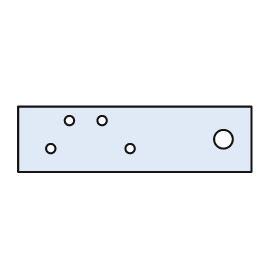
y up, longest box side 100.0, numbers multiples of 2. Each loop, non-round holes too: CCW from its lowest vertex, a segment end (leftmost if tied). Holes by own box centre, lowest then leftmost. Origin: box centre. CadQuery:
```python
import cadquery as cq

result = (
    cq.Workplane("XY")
    .moveTo(-50.0, -14.0)
    .lineTo(50.0, -14.0)
    .lineTo(50.0, 14.0)
    .lineTo(-50.0, 14.0)
    .close()
    .moveTo(-36.0, -4.0)
    .circle(2.0)
    .moveTo(-2.0, -4.0)
    .circle(2.0)
    .moveTo(38.0, 0.0)
    .circle(4.0)
    .moveTo(-28.0, 8.0)
    .circle(2.0)
    .moveTo(-14.0, 8.0)
    .circle(2.0)
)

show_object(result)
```